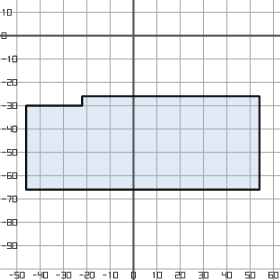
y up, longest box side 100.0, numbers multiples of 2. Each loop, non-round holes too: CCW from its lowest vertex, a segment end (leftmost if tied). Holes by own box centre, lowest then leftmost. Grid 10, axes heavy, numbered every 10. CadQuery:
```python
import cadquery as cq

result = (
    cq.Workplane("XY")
    .moveTo(-46.0, -66.0)
    .lineTo(54.0, -66.0)
    .lineTo(54.0, -26.0)
    .lineTo(-22.0, -26.0)
    .lineTo(-22.0, -30.0)
    .lineTo(-46.0, -30.0)
    .close()
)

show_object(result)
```